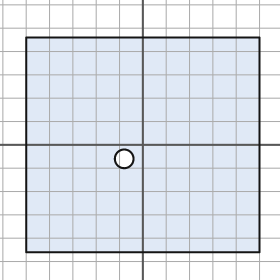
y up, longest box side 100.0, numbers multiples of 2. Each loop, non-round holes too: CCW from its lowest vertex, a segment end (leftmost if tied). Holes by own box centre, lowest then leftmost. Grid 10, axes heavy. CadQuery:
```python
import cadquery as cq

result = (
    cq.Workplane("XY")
    .moveTo(-50.0, -46.0)
    .lineTo(50.0, -46.0)
    .lineTo(50.0, 46.0)
    .lineTo(-50.0, 46.0)
    .close()
    .moveTo(-8.0, -6.0)
    .circle(4.0)
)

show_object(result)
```